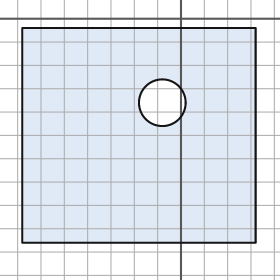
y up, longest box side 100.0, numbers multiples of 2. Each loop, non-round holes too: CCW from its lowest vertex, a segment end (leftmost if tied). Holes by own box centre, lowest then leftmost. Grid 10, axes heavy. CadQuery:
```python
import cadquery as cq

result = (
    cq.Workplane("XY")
    .moveTo(-68.0, -96.0)
    .lineTo(32.0, -96.0)
    .lineTo(32.0, -4.0)
    .lineTo(-68.0, -4.0)
    .close()
    .moveTo(-8.0, -36.0)
    .circle(10.0)
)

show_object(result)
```